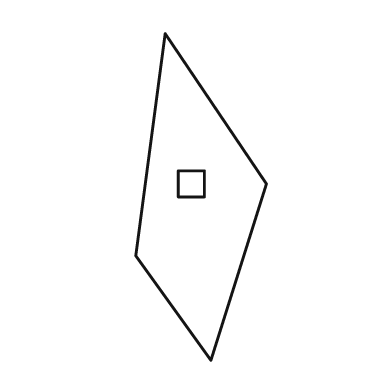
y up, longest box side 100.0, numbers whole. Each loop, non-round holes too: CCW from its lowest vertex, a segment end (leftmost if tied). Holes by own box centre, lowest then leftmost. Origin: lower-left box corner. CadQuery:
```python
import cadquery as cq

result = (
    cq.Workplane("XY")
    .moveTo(23.0, 0.0)
    .lineTo(40.0, 54.0)
    .lineTo(9.0, 100.0)
    .lineTo(0.0, 32.0)
    .close()
    .moveTo(13.0, 50.0)
    .lineTo(21.0, 50.0)
    .lineTo(21.0, 58.0)
    .lineTo(13.0, 58.0)
    .close()
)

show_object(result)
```